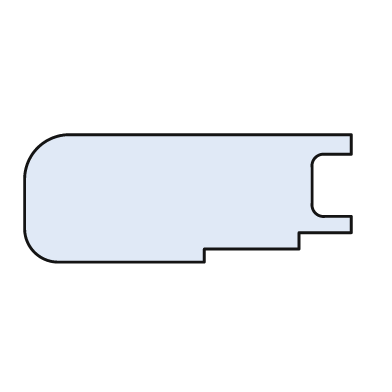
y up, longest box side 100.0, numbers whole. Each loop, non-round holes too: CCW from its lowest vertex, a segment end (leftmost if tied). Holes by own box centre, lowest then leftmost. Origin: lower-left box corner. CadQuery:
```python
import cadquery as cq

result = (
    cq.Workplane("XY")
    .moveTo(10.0, 0.0)
    .lineTo(55.0, 0.0)
    .lineTo(55.0, 4.0)
    .lineTo(84.0, 4.0)
    .lineTo(84.0, 9.0)
    .lineTo(100.0, 9.0)
    .lineTo(100.0, 14.0)
    .lineTo(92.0, 14.0)
    .threePointArc((89.0, 15.0), (88.0, 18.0))
    .lineTo(88.0, 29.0)
    .threePointArc((89.0, 32.0), (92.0, 33.0))
    .lineTo(100.0, 33.0)
    .lineTo(100.0, 39.0)
    .lineTo(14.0, 39.0)
    .threePointArc((4.0, 35.0), (0.0, 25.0))
    .lineTo(0.0, 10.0)
    .threePointArc((3.0, 3.0), (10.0, 0.0))
    .close()
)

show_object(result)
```